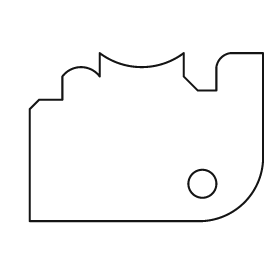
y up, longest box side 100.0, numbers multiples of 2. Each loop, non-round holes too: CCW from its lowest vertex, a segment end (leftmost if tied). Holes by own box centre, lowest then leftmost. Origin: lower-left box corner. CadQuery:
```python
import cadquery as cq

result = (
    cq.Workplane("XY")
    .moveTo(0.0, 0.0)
    .lineTo(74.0, 0.0)
    .threePointArc((92.0, 8.0), (100.0, 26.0))
    .lineTo(100.0, 72.0)
    .lineTo(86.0, 72.0)
    .threePointArc((82.0, 70.0), (80.0, 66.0))
    .lineTo(80.0, 56.0)
    .lineTo(72.0, 56.0)
    .lineTo(66.0, 62.0)
    .lineTo(66.0, 72.0)
    .threePointArc((48.0, 66.0), (30.0, 72.0))
    .lineTo(30.0, 62.0)
    .threePointArc((22.0, 66.0), (14.0, 62.0))
    .lineTo(14.0, 52.0)
    .lineTo(4.0, 52.0)
    .lineTo(0.0, 48.0)
    .close()
    .moveTo(74.0, 16.0)
    .circle(6.0)
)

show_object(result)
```